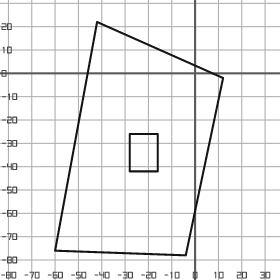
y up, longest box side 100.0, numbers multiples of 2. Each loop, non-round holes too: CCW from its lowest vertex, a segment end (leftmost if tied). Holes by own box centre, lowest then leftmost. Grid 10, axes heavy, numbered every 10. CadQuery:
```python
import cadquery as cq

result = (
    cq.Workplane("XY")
    .moveTo(-4.0, -78.0)
    .lineTo(12.0, -2.0)
    .lineTo(-42.0, 22.0)
    .lineTo(-60.0, -76.0)
    .close()
    .moveTo(-28.0, -42.0)
    .lineTo(-16.0, -42.0)
    .lineTo(-16.0, -26.0)
    .lineTo(-28.0, -26.0)
    .close()
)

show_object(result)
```